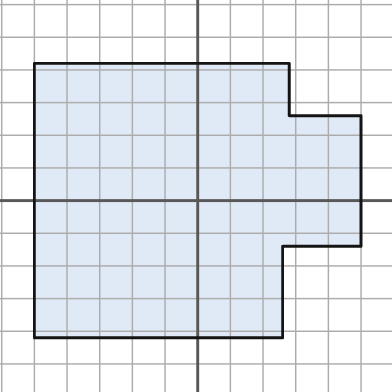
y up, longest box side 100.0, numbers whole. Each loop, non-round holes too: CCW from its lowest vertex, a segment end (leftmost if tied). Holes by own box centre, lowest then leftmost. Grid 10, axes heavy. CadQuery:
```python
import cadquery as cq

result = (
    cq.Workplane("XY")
    .moveTo(-50.0, -42.0)
    .lineTo(26.0, -42.0)
    .lineTo(26.0, -14.0)
    .lineTo(50.0, -14.0)
    .lineTo(50.0, 26.0)
    .lineTo(28.0, 26.0)
    .lineTo(28.0, 42.0)
    .lineTo(-50.0, 42.0)
    .close()
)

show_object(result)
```